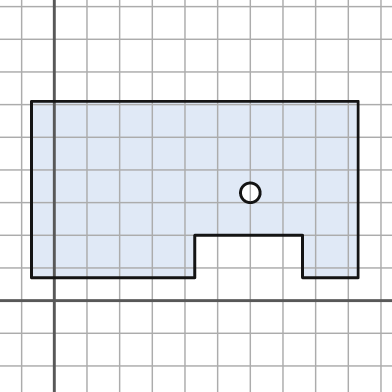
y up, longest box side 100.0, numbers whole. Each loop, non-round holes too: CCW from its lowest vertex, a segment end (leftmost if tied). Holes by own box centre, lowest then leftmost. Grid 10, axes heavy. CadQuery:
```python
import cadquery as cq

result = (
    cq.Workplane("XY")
    .moveTo(-7.0, 7.0)
    .lineTo(43.0, 7.0)
    .lineTo(43.0, 20.0)
    .lineTo(76.0, 20.0)
    .lineTo(76.0, 7.0)
    .lineTo(93.0, 7.0)
    .lineTo(93.0, 61.0)
    .lineTo(-7.0, 61.0)
    .close()
    .moveTo(60.0, 33.0)
    .circle(3.0)
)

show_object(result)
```